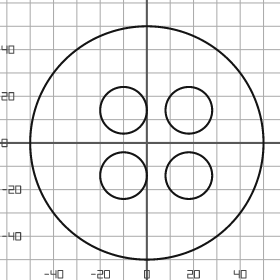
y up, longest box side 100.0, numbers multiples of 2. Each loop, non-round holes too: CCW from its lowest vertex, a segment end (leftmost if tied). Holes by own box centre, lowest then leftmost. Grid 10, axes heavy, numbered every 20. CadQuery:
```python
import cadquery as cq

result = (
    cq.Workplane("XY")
    .moveTo(0.0, 0.0)
    .circle(50.0)
    .moveTo(-10.0, -14.0)
    .circle(10.0)
    .moveTo(18.0, -14.0)
    .circle(10.0)
    .moveTo(-10.0, 14.0)
    .circle(10.0)
    .moveTo(18.0, 14.0)
    .circle(10.0)
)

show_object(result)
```